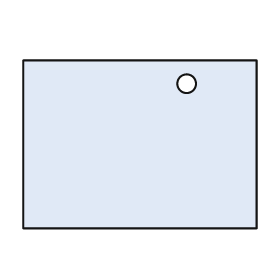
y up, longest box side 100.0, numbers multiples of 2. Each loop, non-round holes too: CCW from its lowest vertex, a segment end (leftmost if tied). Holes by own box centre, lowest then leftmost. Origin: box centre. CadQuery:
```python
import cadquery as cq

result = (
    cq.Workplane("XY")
    .moveTo(-50.0, -36.0)
    .lineTo(50.0, -36.0)
    .lineTo(50.0, 36.0)
    .lineTo(-50.0, 36.0)
    .close()
    .moveTo(20.0, 26.0)
    .circle(4.0)
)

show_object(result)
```